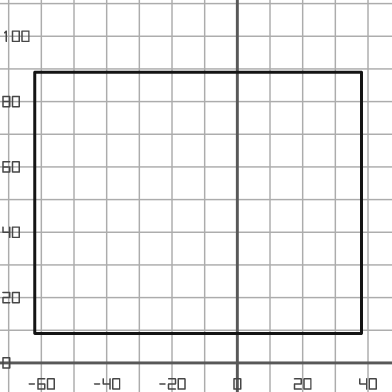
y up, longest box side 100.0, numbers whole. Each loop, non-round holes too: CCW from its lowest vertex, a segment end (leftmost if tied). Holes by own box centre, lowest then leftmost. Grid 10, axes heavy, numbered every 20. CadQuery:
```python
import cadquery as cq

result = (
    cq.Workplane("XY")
    .moveTo(-62.0, 9.0)
    .lineTo(38.0, 9.0)
    .lineTo(38.0, 89.0)
    .lineTo(-62.0, 89.0)
    .close()
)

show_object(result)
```